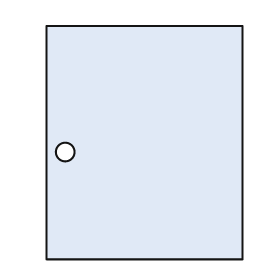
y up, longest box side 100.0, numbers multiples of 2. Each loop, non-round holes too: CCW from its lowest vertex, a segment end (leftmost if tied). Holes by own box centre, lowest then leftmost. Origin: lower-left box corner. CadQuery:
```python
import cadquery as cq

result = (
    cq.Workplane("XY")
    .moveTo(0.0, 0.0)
    .lineTo(84.0, 0.0)
    .lineTo(84.0, 100.0)
    .lineTo(0.0, 100.0)
    .close()
    .moveTo(8.0, 46.0)
    .circle(4.0)
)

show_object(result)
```